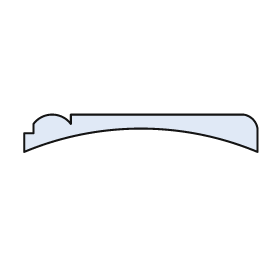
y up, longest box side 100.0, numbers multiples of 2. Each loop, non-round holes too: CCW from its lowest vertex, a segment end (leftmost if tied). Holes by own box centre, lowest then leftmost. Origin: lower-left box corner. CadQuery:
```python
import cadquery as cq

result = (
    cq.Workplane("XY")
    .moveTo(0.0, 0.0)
    .threePointArc((50.0, 10.0), (100.0, 0.0))
    .lineTo(100.0, 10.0)
    .threePointArc((98.0, 14.0), (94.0, 16.0))
    .lineTo(20.0, 16.0)
    .lineTo(20.0, 12.0)
    .threePointArc((12.0, 16.0), (4.0, 12.0))
    .lineTo(4.0, 8.0)
    .lineTo(0.0, 8.0)
    .close()
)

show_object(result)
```